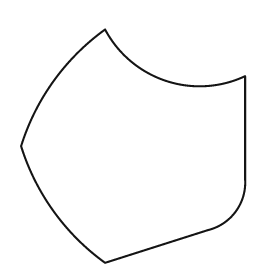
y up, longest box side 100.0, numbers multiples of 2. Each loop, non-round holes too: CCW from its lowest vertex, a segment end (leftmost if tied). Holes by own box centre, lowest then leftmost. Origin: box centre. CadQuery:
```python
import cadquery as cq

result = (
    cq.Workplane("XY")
    .moveTo(-12.0, -50.0)
    .lineTo(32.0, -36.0)
    .threePointArc((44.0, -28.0), (48.0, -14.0))
    .lineTo(48.0, 30.0)
    .threePointArc((14.0, 28.0), (-12.0, 50.0))
    .threePointArc((-34.0, 28.0), (-48.0, 0.0))
    .threePointArc((-34.0, -28.0), (-12.0, -50.0))
    .close()
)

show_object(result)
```